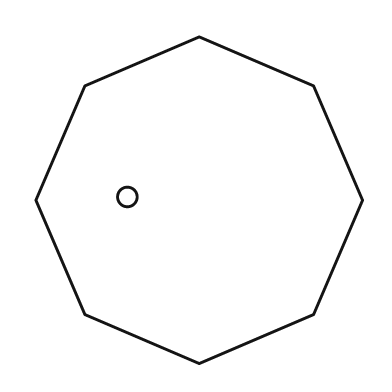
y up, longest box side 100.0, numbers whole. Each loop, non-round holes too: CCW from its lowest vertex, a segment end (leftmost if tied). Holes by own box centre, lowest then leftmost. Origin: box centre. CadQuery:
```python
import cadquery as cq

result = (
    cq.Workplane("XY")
    .moveTo(0.0, -50.0)
    .lineTo(35.0, -35.0)
    .lineTo(50.0, 0.0)
    .lineTo(35.0, 35.0)
    .lineTo(0.0, 50.0)
    .lineTo(-35.0, 35.0)
    .lineTo(-50.0, 0.0)
    .lineTo(-35.0, -35.0)
    .close()
    .moveTo(-22.0, 1.0)
    .circle(3.0)
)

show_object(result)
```